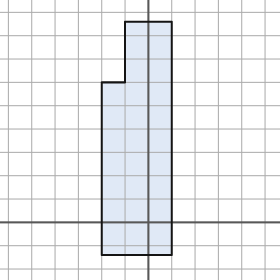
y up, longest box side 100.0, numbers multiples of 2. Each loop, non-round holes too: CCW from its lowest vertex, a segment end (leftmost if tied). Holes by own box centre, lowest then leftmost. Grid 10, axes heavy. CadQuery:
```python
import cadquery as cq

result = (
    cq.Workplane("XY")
    .moveTo(-20.0, -14.0)
    .lineTo(10.0, -14.0)
    .lineTo(10.0, 86.0)
    .lineTo(-10.0, 86.0)
    .lineTo(-10.0, 60.0)
    .lineTo(-20.0, 60.0)
    .close()
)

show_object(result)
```